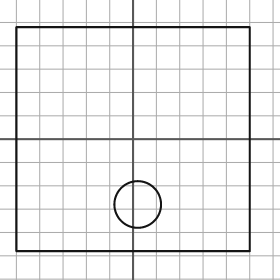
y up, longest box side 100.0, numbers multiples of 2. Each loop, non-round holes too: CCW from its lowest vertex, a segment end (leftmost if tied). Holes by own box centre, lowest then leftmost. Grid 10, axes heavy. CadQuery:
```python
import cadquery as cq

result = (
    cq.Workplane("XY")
    .moveTo(-50.0, -48.0)
    .lineTo(50.0, -48.0)
    .lineTo(50.0, 48.0)
    .lineTo(-50.0, 48.0)
    .close()
    .moveTo(2.0, -28.0)
    .circle(10.0)
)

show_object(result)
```